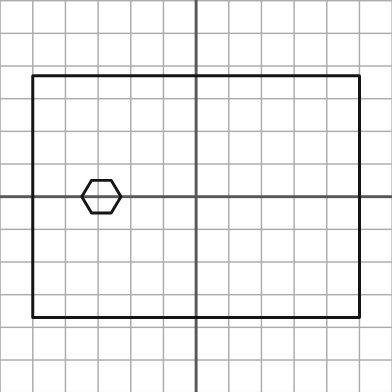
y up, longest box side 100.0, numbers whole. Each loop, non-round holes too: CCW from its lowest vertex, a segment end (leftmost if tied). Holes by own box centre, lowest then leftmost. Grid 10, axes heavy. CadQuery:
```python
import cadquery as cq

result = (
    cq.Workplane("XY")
    .moveTo(-50.0, -37.0)
    .lineTo(50.0, -37.0)
    .lineTo(50.0, 37.0)
    .lineTo(-50.0, 37.0)
    .close()
    .moveTo(-32.0, -5.0)
    .lineTo(-26.0, -5.0)
    .lineTo(-23.0, 0.0)
    .lineTo(-26.0, 5.0)
    .lineTo(-32.0, 5.0)
    .lineTo(-35.0, 0.0)
    .close()
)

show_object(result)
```